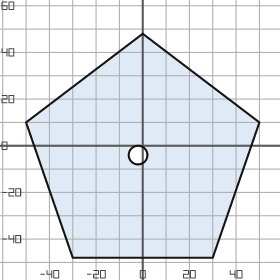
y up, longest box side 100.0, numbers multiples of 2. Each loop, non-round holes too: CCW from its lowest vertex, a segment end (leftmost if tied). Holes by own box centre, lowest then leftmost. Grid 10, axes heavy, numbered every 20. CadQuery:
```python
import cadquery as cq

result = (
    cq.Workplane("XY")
    .moveTo(-30.0, -48.0)
    .lineTo(30.0, -48.0)
    .lineTo(50.0, 10.0)
    .lineTo(0.0, 48.0)
    .lineTo(-50.0, 10.0)
    .close()
    .moveTo(-2.0, -4.0)
    .circle(4.0)
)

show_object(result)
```